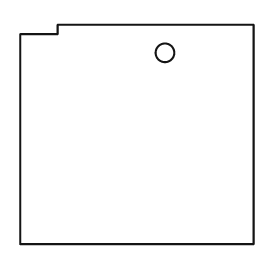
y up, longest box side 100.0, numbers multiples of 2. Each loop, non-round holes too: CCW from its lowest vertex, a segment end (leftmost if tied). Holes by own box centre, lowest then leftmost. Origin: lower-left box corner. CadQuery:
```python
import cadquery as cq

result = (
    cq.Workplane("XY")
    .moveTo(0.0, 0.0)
    .lineTo(100.0, 0.0)
    .lineTo(100.0, 94.0)
    .lineTo(16.0, 94.0)
    .lineTo(16.0, 90.0)
    .lineTo(0.0, 90.0)
    .close()
    .moveTo(62.0, 82.0)
    .circle(4.0)
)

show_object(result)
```